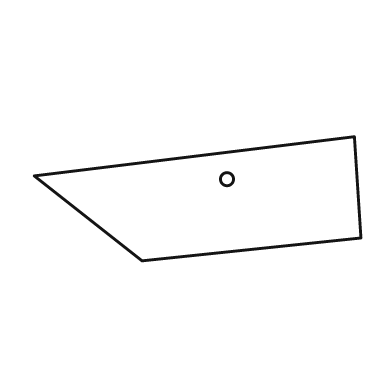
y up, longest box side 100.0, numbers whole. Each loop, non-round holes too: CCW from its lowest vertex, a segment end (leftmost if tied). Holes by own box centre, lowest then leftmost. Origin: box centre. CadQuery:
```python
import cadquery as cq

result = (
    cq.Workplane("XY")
    .moveTo(-17.0, -19.0)
    .lineTo(50.0, -12.0)
    .lineTo(48.0, 19.0)
    .lineTo(-50.0, 7.0)
    .close()
    .moveTo(9.0, 6.0)
    .circle(2.0)
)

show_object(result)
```